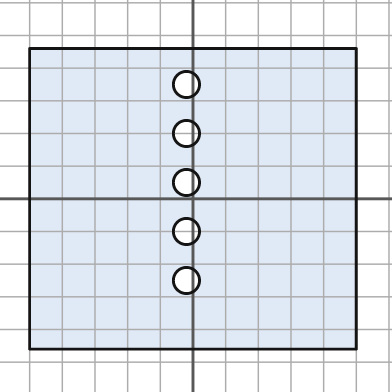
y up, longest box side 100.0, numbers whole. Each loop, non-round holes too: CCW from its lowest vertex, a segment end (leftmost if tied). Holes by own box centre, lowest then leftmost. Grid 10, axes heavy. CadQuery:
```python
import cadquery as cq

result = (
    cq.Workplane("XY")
    .moveTo(-50.0, -46.0)
    .lineTo(50.0, -46.0)
    .lineTo(50.0, 46.0)
    .lineTo(-50.0, 46.0)
    .close()
    .moveTo(-2.0, -25.0)
    .circle(4.0)
    .moveTo(-2.0, -10.0)
    .circle(4.0)
    .moveTo(-2.0, 5.0)
    .circle(4.0)
    .moveTo(-2.0, 20.0)
    .circle(4.0)
    .moveTo(-2.0, 35.0)
    .circle(4.0)
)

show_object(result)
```